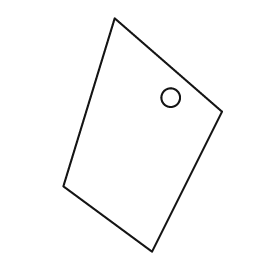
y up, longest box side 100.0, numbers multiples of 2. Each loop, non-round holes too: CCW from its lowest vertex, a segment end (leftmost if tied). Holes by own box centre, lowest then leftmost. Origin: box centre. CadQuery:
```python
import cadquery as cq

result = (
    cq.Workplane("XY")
    .moveTo(4.0, -50.0)
    .lineTo(34.0, 10.0)
    .lineTo(-12.0, 50.0)
    .lineTo(-34.0, -22.0)
    .close()
    .moveTo(12.0, 16.0)
    .circle(4.0)
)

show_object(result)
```